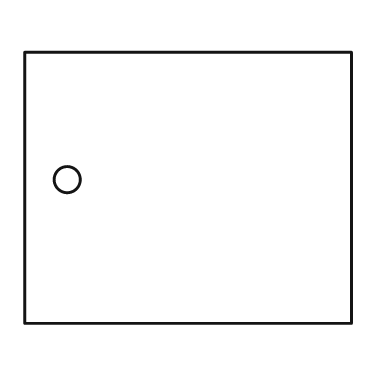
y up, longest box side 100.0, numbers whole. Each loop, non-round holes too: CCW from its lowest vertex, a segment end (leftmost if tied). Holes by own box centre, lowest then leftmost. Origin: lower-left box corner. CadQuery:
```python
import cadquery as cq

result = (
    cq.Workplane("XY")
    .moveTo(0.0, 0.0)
    .lineTo(100.0, 0.0)
    .lineTo(100.0, 83.0)
    .lineTo(0.0, 83.0)
    .close()
    .moveTo(13.0, 44.0)
    .circle(4.0)
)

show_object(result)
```